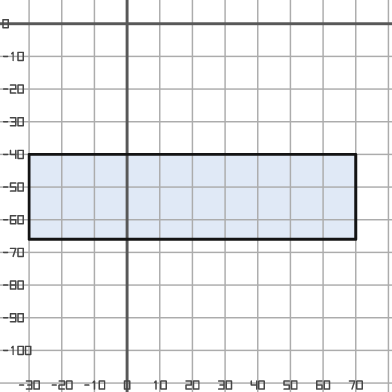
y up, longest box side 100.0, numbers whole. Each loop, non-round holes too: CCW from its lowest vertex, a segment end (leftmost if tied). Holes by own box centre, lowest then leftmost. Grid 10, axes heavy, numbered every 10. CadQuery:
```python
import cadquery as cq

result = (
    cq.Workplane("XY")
    .moveTo(-30.0, -66.0)
    .lineTo(70.0, -66.0)
    .lineTo(70.0, -40.0)
    .lineTo(-30.0, -40.0)
    .close()
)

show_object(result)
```